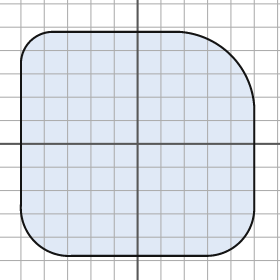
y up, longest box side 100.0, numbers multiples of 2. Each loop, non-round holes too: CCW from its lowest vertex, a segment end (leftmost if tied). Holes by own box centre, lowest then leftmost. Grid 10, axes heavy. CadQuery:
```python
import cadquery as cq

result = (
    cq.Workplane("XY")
    .moveTo(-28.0, -48.0)
    .lineTo(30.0, -48.0)
    .threePointArc((44.0, -42.0), (50.0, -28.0))
    .lineTo(50.0, 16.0)
    .threePointArc((40.0, 38.0), (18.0, 48.0))
    .lineTo(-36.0, 48.0)
    .threePointArc((-46.0, 44.0), (-50.0, 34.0))
    .lineTo(-50.0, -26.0)
    .threePointArc((-44.0, -42.0), (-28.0, -48.0))
    .close()
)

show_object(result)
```